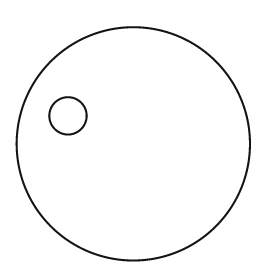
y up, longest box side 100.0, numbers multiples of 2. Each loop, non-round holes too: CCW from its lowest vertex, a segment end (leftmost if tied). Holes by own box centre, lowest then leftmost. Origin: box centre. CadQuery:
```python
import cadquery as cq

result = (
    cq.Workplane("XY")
    .moveTo(0.0, 0.0)
    .circle(50.0)
    .moveTo(-28.0, 12.0)
    .circle(8.0)
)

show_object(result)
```